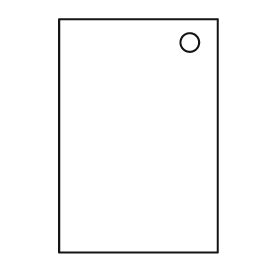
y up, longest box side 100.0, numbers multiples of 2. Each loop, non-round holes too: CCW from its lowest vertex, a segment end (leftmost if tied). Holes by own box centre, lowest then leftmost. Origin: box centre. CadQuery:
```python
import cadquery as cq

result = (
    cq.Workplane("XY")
    .moveTo(-34.0, -50.0)
    .lineTo(34.0, -50.0)
    .lineTo(34.0, 50.0)
    .lineTo(-34.0, 50.0)
    .close()
    .moveTo(22.0, 40.0)
    .circle(4.0)
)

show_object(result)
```